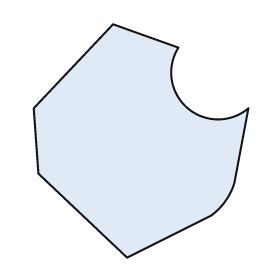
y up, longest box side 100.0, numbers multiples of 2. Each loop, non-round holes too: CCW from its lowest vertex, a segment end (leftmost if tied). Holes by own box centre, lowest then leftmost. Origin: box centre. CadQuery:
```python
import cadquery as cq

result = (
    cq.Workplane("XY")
    .moveTo(-6.0, -50.0)
    .lineTo(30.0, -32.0)
    .threePointArc((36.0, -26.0), (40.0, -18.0))
    .lineTo(46.0, 14.0)
    .threePointArc((20.0, 14.0), (16.0, 40.0))
    .lineTo(-12.0, 50.0)
    .lineTo(-46.0, 14.0)
    .lineTo(-44.0, -14.0)
    .close()
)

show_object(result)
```